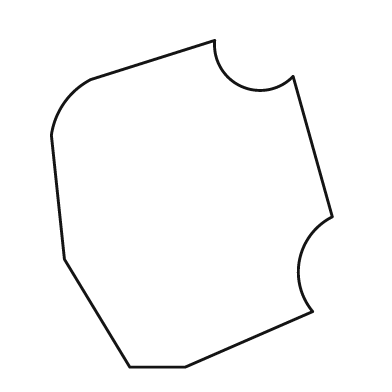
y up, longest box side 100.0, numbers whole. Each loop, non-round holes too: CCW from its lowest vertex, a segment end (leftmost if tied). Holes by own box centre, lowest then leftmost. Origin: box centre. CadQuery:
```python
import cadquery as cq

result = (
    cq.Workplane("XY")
    .moveTo(-19.0, -50.0)
    .lineTo(-2.0, -50.0)
    .lineTo(37.0, -33.0)
    .threePointArc((33.0, -17.0), (43.0, -4.0))
    .lineTo(31.0, 39.0)
    .threePointArc((15.0, 36.0), (7.0, 50.0))
    .lineTo(-31.0, 38.0)
    .threePointArc((-39.0, 31.0), (-43.0, 21.0))
    .lineTo(-39.0, -17.0)
    .close()
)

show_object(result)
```